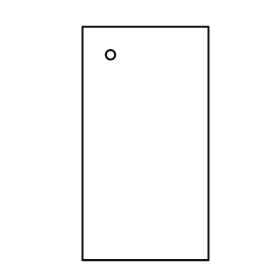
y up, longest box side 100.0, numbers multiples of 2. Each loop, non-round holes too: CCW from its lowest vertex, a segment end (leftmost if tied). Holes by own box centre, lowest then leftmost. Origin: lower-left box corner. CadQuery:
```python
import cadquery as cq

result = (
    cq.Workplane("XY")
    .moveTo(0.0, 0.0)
    .lineTo(54.0, 0.0)
    .lineTo(54.0, 100.0)
    .lineTo(0.0, 100.0)
    .close()
    .moveTo(12.0, 88.0)
    .circle(2.0)
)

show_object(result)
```